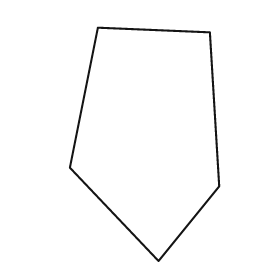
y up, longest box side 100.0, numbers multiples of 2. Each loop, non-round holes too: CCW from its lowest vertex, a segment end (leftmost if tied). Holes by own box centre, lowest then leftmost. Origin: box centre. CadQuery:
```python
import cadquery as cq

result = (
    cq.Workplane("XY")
    .moveTo(6.0, -50.0)
    .lineTo(32.0, -18.0)
    .lineTo(28.0, 48.0)
    .lineTo(-20.0, 50.0)
    .lineTo(-32.0, -10.0)
    .close()
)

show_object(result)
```